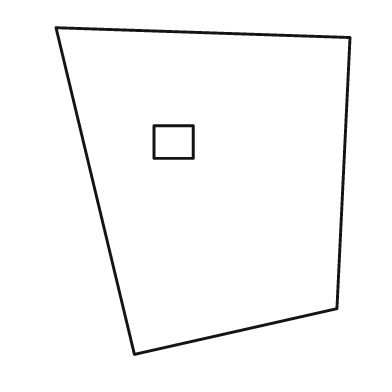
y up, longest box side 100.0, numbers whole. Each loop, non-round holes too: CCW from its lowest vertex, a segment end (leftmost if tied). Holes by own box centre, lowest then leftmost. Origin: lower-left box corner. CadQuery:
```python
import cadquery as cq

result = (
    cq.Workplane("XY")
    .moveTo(24.0, 0.0)
    .lineTo(86.0, 14.0)
    .lineTo(90.0, 97.0)
    .lineTo(0.0, 100.0)
    .close()
    .moveTo(30.0, 60.0)
    .lineTo(42.0, 60.0)
    .lineTo(42.0, 70.0)
    .lineTo(30.0, 70.0)
    .close()
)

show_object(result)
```